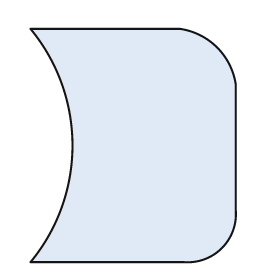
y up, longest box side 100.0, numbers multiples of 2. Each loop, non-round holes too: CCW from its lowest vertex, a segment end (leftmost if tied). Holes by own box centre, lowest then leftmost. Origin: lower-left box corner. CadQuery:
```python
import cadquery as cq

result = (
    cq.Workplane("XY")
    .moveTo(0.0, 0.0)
    .lineTo(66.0, 0.0)
    .threePointArc((82.0, 6.0), (88.0, 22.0))
    .lineTo(88.0, 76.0)
    .threePointArc((80.0, 92.0), (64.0, 100.0))
    .lineTo(0.0, 100.0)
    .threePointArc((18.0, 50.0), (0.0, 0.0))
    .close()
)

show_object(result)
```